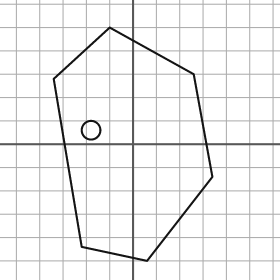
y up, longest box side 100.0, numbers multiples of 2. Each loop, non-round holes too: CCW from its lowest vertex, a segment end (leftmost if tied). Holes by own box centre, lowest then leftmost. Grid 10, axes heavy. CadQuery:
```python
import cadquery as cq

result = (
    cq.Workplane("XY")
    .moveTo(6.0, -50.0)
    .lineTo(34.0, -14.0)
    .lineTo(26.0, 30.0)
    .lineTo(-10.0, 50.0)
    .lineTo(-34.0, 28.0)
    .lineTo(-22.0, -44.0)
    .close()
    .moveTo(-18.0, 6.0)
    .circle(4.0)
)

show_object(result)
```